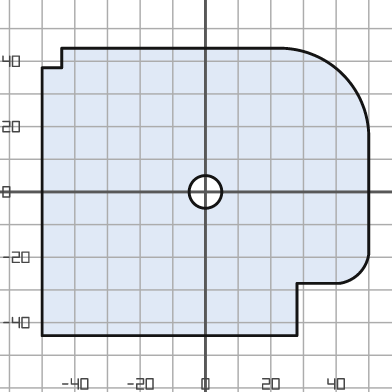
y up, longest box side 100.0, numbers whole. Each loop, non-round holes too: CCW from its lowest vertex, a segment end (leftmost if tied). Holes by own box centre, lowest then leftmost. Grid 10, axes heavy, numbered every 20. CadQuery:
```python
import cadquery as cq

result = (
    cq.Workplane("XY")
    .moveTo(-50.0, -44.0)
    .lineTo(28.0, -44.0)
    .lineTo(28.0, -28.0)
    .lineTo(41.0, -28.0)
    .threePointArc((47.0, -25.0), (50.0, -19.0))
    .lineTo(50.0, 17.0)
    .threePointArc((42.0, 36.0), (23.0, 44.0))
    .lineTo(-44.0, 44.0)
    .lineTo(-44.0, 38.0)
    .lineTo(-50.0, 38.0)
    .close()
    .moveTo(0.0, 0.0)
    .circle(5.0)
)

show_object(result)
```